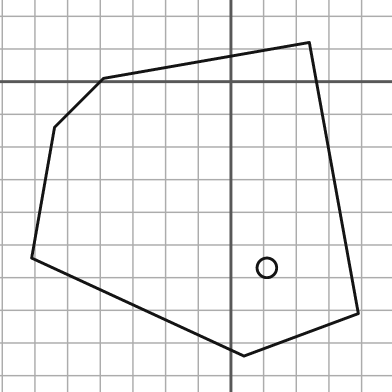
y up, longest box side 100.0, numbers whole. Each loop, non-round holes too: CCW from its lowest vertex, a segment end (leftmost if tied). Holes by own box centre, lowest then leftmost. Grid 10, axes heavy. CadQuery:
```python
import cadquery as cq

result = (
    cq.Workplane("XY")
    .moveTo(4.0, -84.0)
    .lineTo(39.0, -71.0)
    .lineTo(24.0, 12.0)
    .lineTo(-39.0, 1.0)
    .lineTo(-54.0, -14.0)
    .lineTo(-61.0, -54.0)
    .close()
    .moveTo(11.0, -57.0)
    .circle(3.0)
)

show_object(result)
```